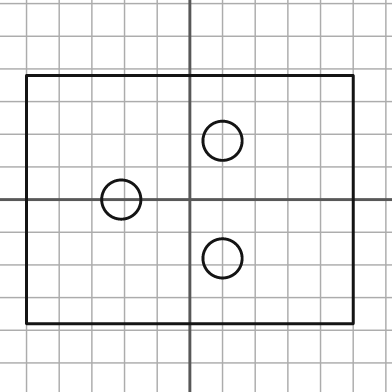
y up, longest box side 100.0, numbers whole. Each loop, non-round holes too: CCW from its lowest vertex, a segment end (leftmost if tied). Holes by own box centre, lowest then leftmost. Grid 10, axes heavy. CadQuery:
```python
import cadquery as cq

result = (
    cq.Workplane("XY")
    .moveTo(-50.0, -38.0)
    .lineTo(50.0, -38.0)
    .lineTo(50.0, 38.0)
    .lineTo(-50.0, 38.0)
    .close()
    .moveTo(10.0, -18.0)
    .circle(6.0)
    .moveTo(-21.0, 0.0)
    .circle(6.0)
    .moveTo(10.0, 18.0)
    .circle(6.0)
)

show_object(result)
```